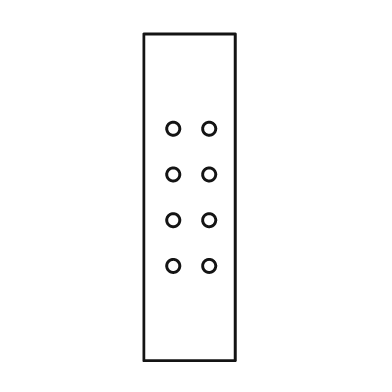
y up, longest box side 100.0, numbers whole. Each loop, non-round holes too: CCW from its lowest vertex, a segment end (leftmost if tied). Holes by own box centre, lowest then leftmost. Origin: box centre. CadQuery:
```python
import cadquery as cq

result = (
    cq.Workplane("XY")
    .moveTo(-14.0, -50.0)
    .lineTo(14.0, -50.0)
    .lineTo(14.0, 50.0)
    .lineTo(-14.0, 50.0)
    .close()
    .moveTo(-5.0, -21.0)
    .circle(2.0)
    .moveTo(6.0, -21.0)
    .circle(2.0)
    .moveTo(-5.0, -7.0)
    .circle(2.0)
    .moveTo(6.0, -7.0)
    .circle(2.0)
    .moveTo(-5.0, 7.0)
    .circle(2.0)
    .moveTo(6.0, 7.0)
    .circle(2.0)
    .moveTo(-5.0, 21.0)
    .circle(2.0)
    .moveTo(6.0, 21.0)
    .circle(2.0)
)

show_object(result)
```